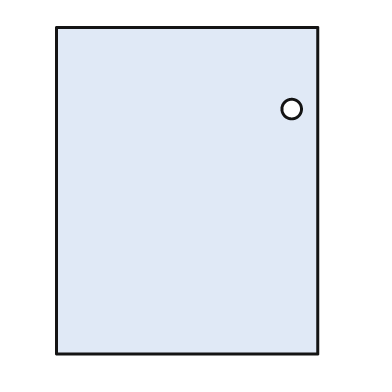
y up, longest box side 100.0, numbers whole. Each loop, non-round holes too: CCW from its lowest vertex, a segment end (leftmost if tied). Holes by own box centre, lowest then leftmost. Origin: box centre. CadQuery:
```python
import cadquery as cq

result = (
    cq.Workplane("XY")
    .moveTo(-40.0, -50.0)
    .lineTo(40.0, -50.0)
    .lineTo(40.0, 50.0)
    .lineTo(-40.0, 50.0)
    .close()
    .moveTo(32.0, 25.0)
    .circle(3.0)
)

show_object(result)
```